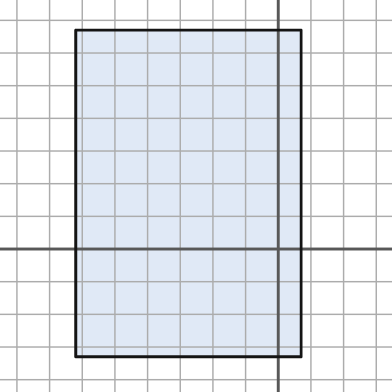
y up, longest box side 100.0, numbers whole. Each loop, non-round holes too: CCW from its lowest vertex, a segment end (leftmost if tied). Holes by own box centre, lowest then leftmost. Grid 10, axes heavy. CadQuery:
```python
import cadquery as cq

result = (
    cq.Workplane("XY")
    .moveTo(-62.0, -33.0)
    .lineTo(7.0, -33.0)
    .lineTo(7.0, 67.0)
    .lineTo(-62.0, 67.0)
    .close()
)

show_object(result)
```